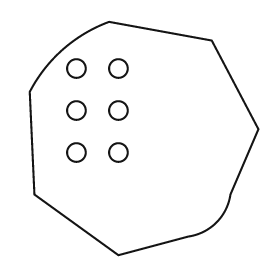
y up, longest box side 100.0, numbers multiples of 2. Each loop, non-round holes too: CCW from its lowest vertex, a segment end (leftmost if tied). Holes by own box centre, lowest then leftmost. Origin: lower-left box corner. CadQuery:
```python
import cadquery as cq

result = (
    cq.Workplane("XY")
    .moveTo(38.0, 0.0)
    .lineTo(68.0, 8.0)
    .threePointArc((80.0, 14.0), (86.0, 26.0))
    .lineTo(98.0, 54.0)
    .lineTo(78.0, 92.0)
    .lineTo(34.0, 100.0)
    .threePointArc((14.0, 88.0), (0.0, 70.0))
    .lineTo(2.0, 26.0)
    .close()
    .moveTo(20.0, 44.0)
    .circle(4.0)
    .moveTo(38.0, 44.0)
    .circle(4.0)
    .moveTo(20.0, 62.0)
    .circle(4.0)
    .moveTo(38.0, 62.0)
    .circle(4.0)
    .moveTo(20.0, 80.0)
    .circle(4.0)
    .moveTo(38.0, 80.0)
    .circle(4.0)
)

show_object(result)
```